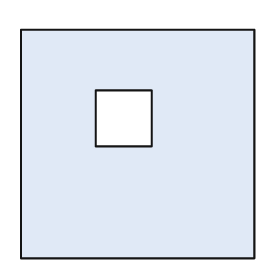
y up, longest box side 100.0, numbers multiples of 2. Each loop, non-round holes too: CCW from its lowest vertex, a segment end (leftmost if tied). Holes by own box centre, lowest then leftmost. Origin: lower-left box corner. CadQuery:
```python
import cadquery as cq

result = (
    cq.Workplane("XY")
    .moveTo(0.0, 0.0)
    .lineTo(100.0, 0.0)
    .lineTo(100.0, 98.0)
    .lineTo(0.0, 98.0)
    .close()
    .moveTo(32.0, 48.0)
    .lineTo(56.0, 48.0)
    .lineTo(56.0, 72.0)
    .lineTo(32.0, 72.0)
    .close()
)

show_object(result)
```